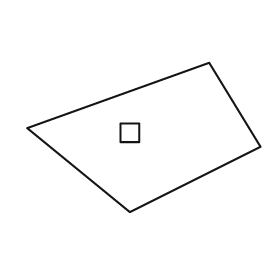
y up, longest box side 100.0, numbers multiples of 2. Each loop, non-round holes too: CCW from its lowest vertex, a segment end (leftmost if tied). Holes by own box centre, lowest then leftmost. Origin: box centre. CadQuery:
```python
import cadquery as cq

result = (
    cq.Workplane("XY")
    .moveTo(-6.0, -32.0)
    .lineTo(50.0, -4.0)
    .lineTo(28.0, 32.0)
    .lineTo(-50.0, 4.0)
    .close()
    .moveTo(-10.0, -2.0)
    .lineTo(-2.0, -2.0)
    .lineTo(-2.0, 6.0)
    .lineTo(-10.0, 6.0)
    .close()
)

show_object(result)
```